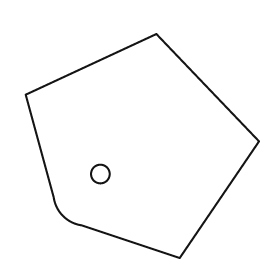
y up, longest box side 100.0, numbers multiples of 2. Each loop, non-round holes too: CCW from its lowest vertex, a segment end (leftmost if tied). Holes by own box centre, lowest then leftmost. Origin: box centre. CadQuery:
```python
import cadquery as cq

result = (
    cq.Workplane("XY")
    .moveTo(16.0, -48.0)
    .lineTo(50.0, 2.0)
    .lineTo(6.0, 48.0)
    .lineTo(-50.0, 22.0)
    .lineTo(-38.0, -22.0)
    .threePointArc((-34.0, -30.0), (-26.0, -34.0))
    .close()
    .moveTo(-18.0, -12.0)
    .circle(4.0)
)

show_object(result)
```